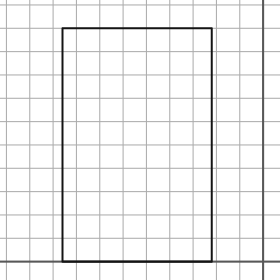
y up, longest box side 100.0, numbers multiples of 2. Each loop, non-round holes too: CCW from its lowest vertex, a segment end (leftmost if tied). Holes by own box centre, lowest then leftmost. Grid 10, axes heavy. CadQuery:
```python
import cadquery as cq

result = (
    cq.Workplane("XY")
    .moveTo(-86.0, 0.0)
    .lineTo(-22.0, 0.0)
    .lineTo(-22.0, 100.0)
    .lineTo(-86.0, 100.0)
    .close()
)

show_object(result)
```